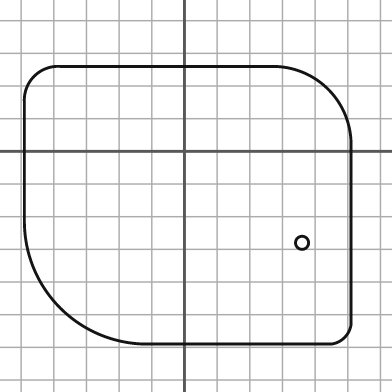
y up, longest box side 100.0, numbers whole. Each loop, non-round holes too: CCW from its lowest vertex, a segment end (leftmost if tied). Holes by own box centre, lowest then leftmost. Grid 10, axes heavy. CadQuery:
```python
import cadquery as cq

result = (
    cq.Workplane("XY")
    .moveTo(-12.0, -59.0)
    .lineTo(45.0, -59.0)
    .threePointArc((49.0, -57.0), (51.0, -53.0))
    .lineTo(51.0, 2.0)
    .threePointArc((44.0, 19.0), (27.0, 26.0))
    .lineTo(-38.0, 26.0)
    .threePointArc((-46.0, 23.0), (-49.0, 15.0))
    .lineTo(-49.0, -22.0)
    .threePointArc((-38.0, -48.0), (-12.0, -59.0))
    .close()
    .moveTo(36.0, -28.0)
    .circle(2.0)
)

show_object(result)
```